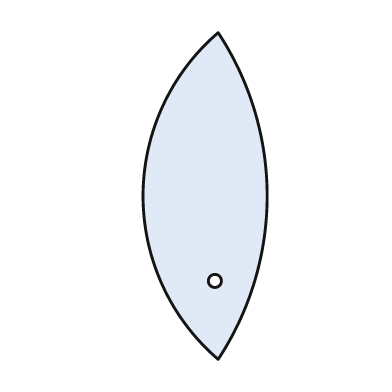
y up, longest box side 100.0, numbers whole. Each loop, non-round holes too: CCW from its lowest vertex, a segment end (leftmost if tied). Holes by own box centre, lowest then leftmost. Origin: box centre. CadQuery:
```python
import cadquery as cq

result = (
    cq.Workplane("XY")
    .moveTo(4.0, -50.0)
    .threePointArc((19.0, 0.0), (4.0, 50.0))
    .threePointArc((-19.0, 0.0), (4.0, -50.0))
    .close()
    .moveTo(3.0, -26.0)
    .circle(2.0)
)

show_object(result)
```